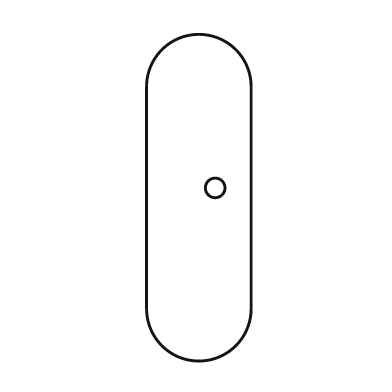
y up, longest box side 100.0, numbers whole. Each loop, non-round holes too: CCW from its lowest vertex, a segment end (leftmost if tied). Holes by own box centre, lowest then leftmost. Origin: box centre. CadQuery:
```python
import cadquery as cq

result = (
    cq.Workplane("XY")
    .moveTo(-16.0, -34.0)
    .threePointArc((0.0, -50.0), (16.0, -34.0))
    .lineTo(16.0, 34.0)
    .threePointArc((0.0, 50.0), (-16.0, 34.0))
    .close()
    .moveTo(5.0, 3.0)
    .circle(3.0)
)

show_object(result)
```